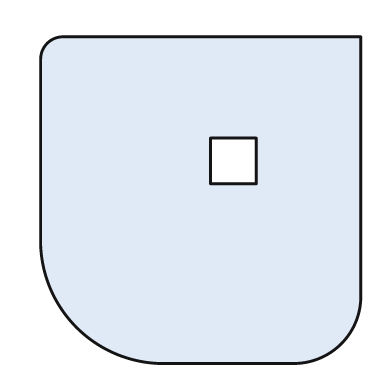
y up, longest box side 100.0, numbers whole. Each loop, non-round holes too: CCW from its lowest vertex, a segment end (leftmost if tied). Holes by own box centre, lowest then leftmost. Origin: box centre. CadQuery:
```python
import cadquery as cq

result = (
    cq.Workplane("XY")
    .moveTo(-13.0, -50.0)
    .lineTo(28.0, -50.0)
    .threePointArc((43.0, -44.0), (49.0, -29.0))
    .lineTo(49.0, 50.0)
    .lineTo(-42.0, 50.0)
    .threePointArc((-47.0, 48.0), (-49.0, 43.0))
    .lineTo(-49.0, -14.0)
    .threePointArc((-38.0, -39.0), (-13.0, -50.0))
    .close()
    .moveTo(3.0, 5.0)
    .lineTo(17.0, 5.0)
    .lineTo(17.0, 19.0)
    .lineTo(3.0, 19.0)
    .close()
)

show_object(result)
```